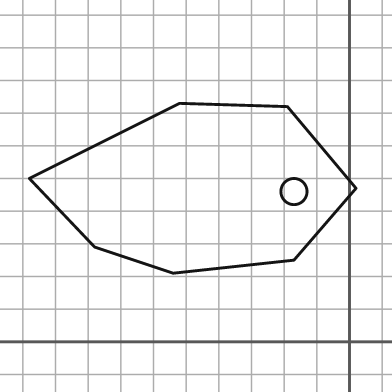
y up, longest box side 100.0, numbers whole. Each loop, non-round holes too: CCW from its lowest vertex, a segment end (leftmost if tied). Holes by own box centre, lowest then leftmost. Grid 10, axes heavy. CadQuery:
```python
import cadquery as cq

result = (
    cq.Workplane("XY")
    .moveTo(-54.0, 21.0)
    .lineTo(-17.0, 25.0)
    .lineTo(2.0, 47.0)
    .lineTo(-19.0, 72.0)
    .lineTo(-52.0, 73.0)
    .lineTo(-98.0, 50.0)
    .lineTo(-78.0, 29.0)
    .close()
    .moveTo(-17.0, 46.0)
    .circle(4.0)
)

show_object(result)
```